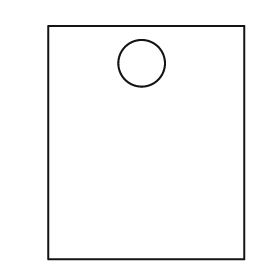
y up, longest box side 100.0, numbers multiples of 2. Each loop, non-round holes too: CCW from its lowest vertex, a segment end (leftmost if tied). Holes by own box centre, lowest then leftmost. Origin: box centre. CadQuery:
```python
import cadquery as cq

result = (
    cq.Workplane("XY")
    .moveTo(-42.0, -50.0)
    .lineTo(42.0, -50.0)
    .lineTo(42.0, 50.0)
    .lineTo(-42.0, 50.0)
    .close()
    .moveTo(-2.0, 34.0)
    .circle(10.0)
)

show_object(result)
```